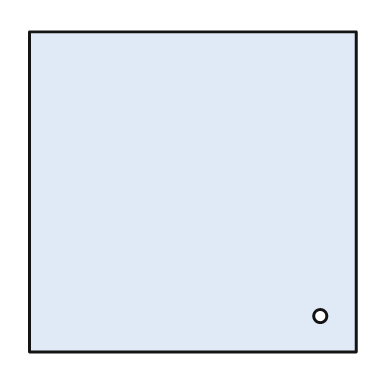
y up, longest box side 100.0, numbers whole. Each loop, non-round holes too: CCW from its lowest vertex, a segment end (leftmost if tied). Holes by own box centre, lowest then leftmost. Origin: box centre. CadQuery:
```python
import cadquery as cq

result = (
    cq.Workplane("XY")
    .moveTo(-50.0, -49.0)
    .lineTo(50.0, -49.0)
    .lineTo(50.0, 49.0)
    .lineTo(-50.0, 49.0)
    .close()
    .moveTo(39.0, -38.0)
    .circle(2.0)
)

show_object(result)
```